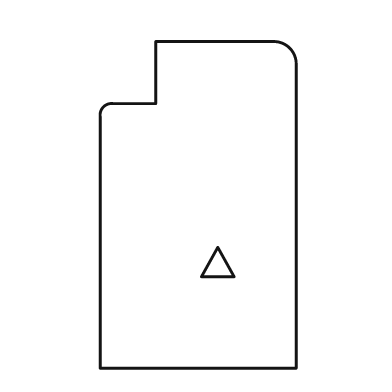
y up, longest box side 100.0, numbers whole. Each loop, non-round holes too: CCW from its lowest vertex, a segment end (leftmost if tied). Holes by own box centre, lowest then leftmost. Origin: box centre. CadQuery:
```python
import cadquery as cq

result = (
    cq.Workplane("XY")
    .moveTo(-30.0, -50.0)
    .lineTo(30.0, -50.0)
    .lineTo(30.0, 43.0)
    .threePointArc((28.0, 48.0), (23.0, 50.0))
    .lineTo(-13.0, 50.0)
    .lineTo(-13.0, 31.0)
    .lineTo(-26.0, 31.0)
    .threePointArc((-29.0, 30.0), (-30.0, 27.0))
    .close()
    .moveTo(1.0, -22.0)
    .lineTo(11.0, -22.0)
    .lineTo(6.0, -13.0)
    .close()
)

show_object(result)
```